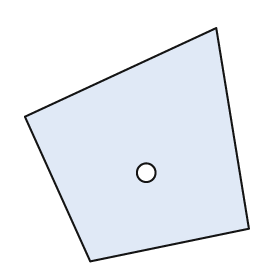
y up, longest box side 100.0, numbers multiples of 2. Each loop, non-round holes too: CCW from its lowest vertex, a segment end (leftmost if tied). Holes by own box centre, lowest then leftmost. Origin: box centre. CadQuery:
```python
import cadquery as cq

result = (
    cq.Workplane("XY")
    .moveTo(-20.0, -50.0)
    .lineTo(48.0, -36.0)
    .lineTo(34.0, 50.0)
    .lineTo(-48.0, 12.0)
    .close()
    .moveTo(4.0, -12.0)
    .circle(4.0)
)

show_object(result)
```